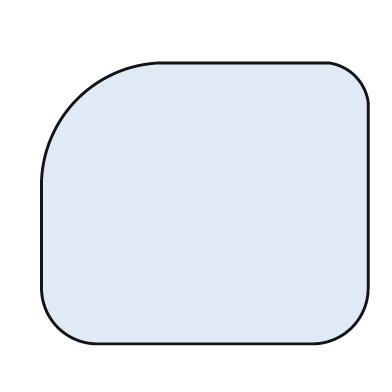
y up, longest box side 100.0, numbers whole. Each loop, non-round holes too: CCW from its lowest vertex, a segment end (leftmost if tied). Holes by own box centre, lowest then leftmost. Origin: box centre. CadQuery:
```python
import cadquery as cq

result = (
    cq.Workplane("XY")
    .moveTo(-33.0, -43.0)
    .lineTo(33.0, -43.0)
    .threePointArc((45.0, -38.0), (50.0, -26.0))
    .lineTo(50.0, 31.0)
    .threePointArc((46.0, 39.0), (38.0, 43.0))
    .lineTo(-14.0, 43.0)
    .threePointArc((-39.0, 32.0), (-50.0, 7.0))
    .lineTo(-50.0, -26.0)
    .threePointArc((-45.0, -38.0), (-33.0, -43.0))
    .close()
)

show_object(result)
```